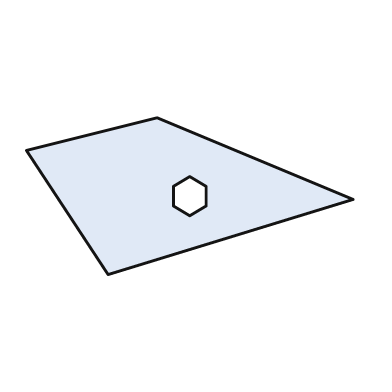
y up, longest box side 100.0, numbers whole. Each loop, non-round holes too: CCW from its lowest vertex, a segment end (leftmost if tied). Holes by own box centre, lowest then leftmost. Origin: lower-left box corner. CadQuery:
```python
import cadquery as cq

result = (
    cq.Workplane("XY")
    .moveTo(25.0, 0.0)
    .lineTo(100.0, 23.0)
    .lineTo(40.0, 48.0)
    .lineTo(0.0, 38.0)
    .close()
    .moveTo(50.0, 18.0)
    .lineTo(55.0, 21.0)
    .lineTo(55.0, 27.0)
    .lineTo(50.0, 30.0)
    .lineTo(45.0, 27.0)
    .lineTo(45.0, 21.0)
    .close()
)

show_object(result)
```